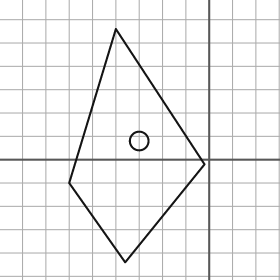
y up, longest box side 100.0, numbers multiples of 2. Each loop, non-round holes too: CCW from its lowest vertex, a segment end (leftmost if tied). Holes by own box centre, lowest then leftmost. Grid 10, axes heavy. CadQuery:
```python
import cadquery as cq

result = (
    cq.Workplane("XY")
    .moveTo(-36.0, -44.0)
    .lineTo(-2.0, -2.0)
    .lineTo(-40.0, 56.0)
    .lineTo(-60.0, -10.0)
    .close()
    .moveTo(-30.0, 8.0)
    .circle(4.0)
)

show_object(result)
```